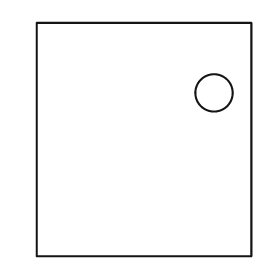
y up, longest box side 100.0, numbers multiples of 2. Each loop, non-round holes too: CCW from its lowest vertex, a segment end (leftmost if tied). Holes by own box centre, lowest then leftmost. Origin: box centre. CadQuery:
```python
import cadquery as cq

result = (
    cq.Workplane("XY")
    .moveTo(-46.0, -50.0)
    .lineTo(46.0, -50.0)
    .lineTo(46.0, 50.0)
    .lineTo(-46.0, 50.0)
    .close()
    .moveTo(30.0, 20.0)
    .circle(8.0)
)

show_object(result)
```